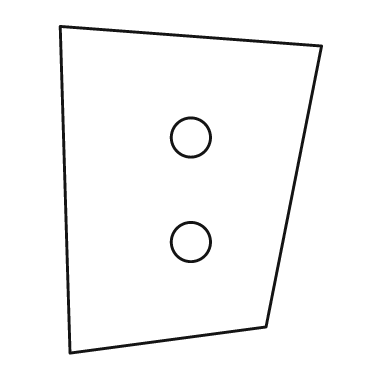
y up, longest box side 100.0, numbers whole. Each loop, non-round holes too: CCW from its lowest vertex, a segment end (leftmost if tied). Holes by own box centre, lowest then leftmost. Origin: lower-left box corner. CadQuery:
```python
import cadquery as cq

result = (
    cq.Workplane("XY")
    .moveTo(3.0, 0.0)
    .lineTo(63.0, 8.0)
    .lineTo(80.0, 94.0)
    .lineTo(0.0, 100.0)
    .close()
    .moveTo(40.0, 34.0)
    .circle(6.0)
    .moveTo(40.0, 66.0)
    .circle(6.0)
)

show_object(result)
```